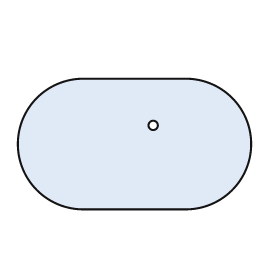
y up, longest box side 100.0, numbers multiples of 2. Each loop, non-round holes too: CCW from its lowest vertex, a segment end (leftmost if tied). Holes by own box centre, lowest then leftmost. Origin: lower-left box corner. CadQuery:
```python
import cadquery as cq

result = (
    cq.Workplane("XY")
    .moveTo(28.0, 0.0)
    .lineTo(72.0, 0.0)
    .threePointArc((100.0, 28.0), (72.0, 56.0))
    .lineTo(28.0, 56.0)
    .threePointArc((0.0, 28.0), (28.0, 0.0))
    .close()
    .moveTo(58.0, 36.0)
    .circle(2.0)
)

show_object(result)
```